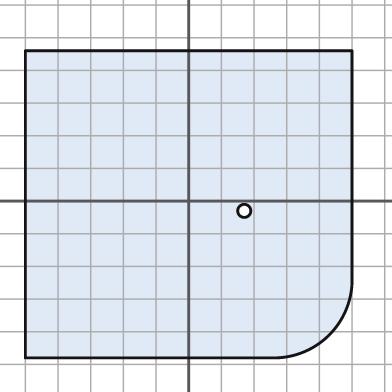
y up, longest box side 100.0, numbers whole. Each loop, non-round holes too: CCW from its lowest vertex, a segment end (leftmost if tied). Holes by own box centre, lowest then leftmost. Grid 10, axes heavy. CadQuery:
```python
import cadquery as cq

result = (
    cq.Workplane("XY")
    .moveTo(-50.0, -48.0)
    .lineTo(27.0, -48.0)
    .threePointArc((43.0, -41.0), (50.0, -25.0))
    .lineTo(50.0, 46.0)
    .lineTo(-50.0, 46.0)
    .close()
    .moveTo(17.0, -3.0)
    .circle(2.0)
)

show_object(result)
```